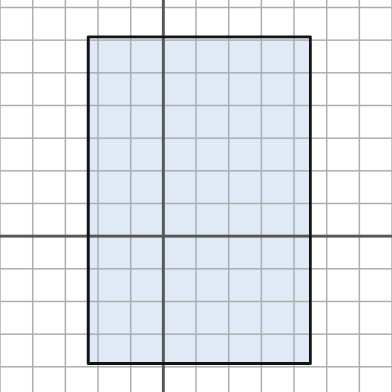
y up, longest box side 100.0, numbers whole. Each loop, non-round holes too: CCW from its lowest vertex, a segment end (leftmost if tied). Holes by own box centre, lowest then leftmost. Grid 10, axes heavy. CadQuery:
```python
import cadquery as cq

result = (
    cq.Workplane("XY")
    .moveTo(-23.0, -39.0)
    .lineTo(45.0, -39.0)
    .lineTo(45.0, 61.0)
    .lineTo(-23.0, 61.0)
    .close()
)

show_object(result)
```